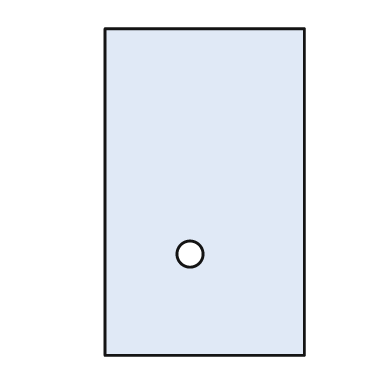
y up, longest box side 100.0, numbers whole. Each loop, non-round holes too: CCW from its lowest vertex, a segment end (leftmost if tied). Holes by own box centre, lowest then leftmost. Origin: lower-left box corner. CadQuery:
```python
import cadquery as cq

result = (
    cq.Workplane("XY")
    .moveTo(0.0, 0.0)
    .lineTo(61.0, 0.0)
    .lineTo(61.0, 100.0)
    .lineTo(0.0, 100.0)
    .close()
    .moveTo(26.0, 31.0)
    .circle(4.0)
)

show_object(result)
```